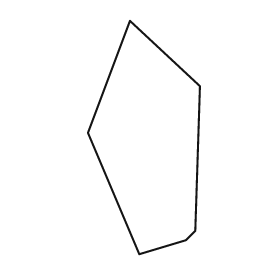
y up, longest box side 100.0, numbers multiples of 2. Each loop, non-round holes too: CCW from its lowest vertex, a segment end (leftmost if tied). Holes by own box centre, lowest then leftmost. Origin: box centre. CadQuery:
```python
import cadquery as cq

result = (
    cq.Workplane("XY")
    .moveTo(-2.0, -50.0)
    .lineTo(18.0, -44.0)
    .lineTo(22.0, -40.0)
    .lineTo(24.0, 22.0)
    .lineTo(-6.0, 50.0)
    .lineTo(-24.0, 2.0)
    .close()
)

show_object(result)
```